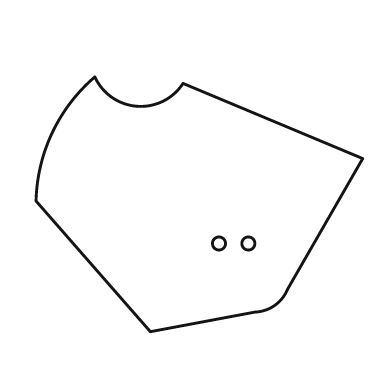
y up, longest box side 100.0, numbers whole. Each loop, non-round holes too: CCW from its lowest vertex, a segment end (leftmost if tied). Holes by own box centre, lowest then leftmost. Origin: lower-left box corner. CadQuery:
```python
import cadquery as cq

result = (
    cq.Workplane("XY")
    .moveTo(35.0, 0.0)
    .lineTo(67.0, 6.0)
    .threePointArc((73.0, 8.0), (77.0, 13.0))
    .lineTo(100.0, 53.0)
    .lineTo(45.0, 76.0)
    .threePointArc((31.0, 69.0), (18.0, 78.0))
    .threePointArc((5.0, 61.0), (0.0, 40.0))
    .close()
    .moveTo(56.0, 27.0)
    .circle(2.0)
    .moveTo(65.0, 27.0)
    .circle(2.0)
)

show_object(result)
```